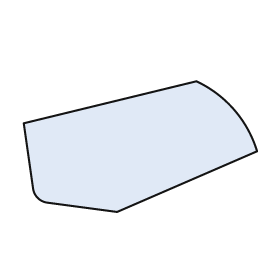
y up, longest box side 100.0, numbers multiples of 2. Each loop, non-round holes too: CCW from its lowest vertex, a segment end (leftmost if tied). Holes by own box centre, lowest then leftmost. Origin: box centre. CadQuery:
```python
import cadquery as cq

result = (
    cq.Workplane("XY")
    .moveTo(-10.0, -28.0)
    .lineTo(50.0, -2.0)
    .threePointArc((40.0, 16.0), (24.0, 28.0))
    .lineTo(-50.0, 10.0)
    .lineTo(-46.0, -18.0)
    .threePointArc((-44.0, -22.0), (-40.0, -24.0))
    .close()
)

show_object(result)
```